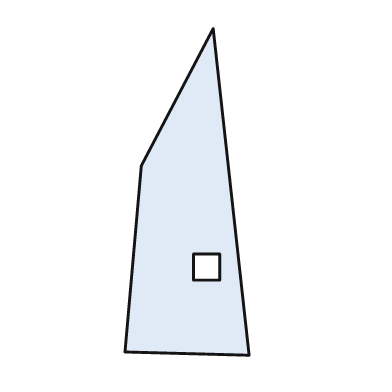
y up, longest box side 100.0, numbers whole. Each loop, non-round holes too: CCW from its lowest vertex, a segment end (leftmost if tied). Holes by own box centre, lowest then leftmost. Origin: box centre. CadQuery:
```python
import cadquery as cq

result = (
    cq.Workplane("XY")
    .moveTo(19.0, -50.0)
    .lineTo(8.0, 50.0)
    .lineTo(-14.0, 8.0)
    .lineTo(-19.0, -49.0)
    .close()
    .moveTo(2.0, -27.0)
    .lineTo(10.0, -27.0)
    .lineTo(10.0, -19.0)
    .lineTo(2.0, -19.0)
    .close()
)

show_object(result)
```